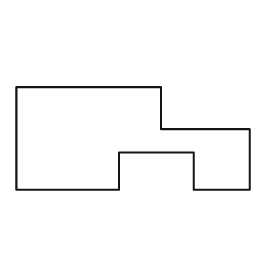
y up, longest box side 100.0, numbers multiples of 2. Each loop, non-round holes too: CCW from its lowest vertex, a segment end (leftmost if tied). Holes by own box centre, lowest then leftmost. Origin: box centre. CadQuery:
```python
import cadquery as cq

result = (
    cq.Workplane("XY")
    .moveTo(-50.0, -22.0)
    .lineTo(-6.0, -22.0)
    .lineTo(-6.0, -6.0)
    .lineTo(26.0, -6.0)
    .lineTo(26.0, -22.0)
    .lineTo(50.0, -22.0)
    .lineTo(50.0, 4.0)
    .lineTo(12.0, 4.0)
    .lineTo(12.0, 22.0)
    .lineTo(-50.0, 22.0)
    .close()
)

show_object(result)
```